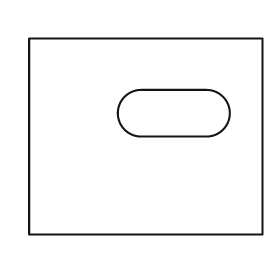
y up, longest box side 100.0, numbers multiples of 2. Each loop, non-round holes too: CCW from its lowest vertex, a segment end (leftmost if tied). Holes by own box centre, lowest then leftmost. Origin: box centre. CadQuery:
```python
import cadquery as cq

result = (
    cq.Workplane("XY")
    .moveTo(-50.0, -42.0)
    .lineTo(50.0, -42.0)
    .lineTo(50.0, 42.0)
    .lineTo(-50.0, 42.0)
    .close()
    .moveTo(-2.0, 0.0)
    .lineTo(26.0, 0.0)
    .threePointArc((36.0, 10.0), (26.0, 20.0))
    .lineTo(-2.0, 20.0)
    .threePointArc((-12.0, 10.0), (-2.0, 0.0))
    .close()
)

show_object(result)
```